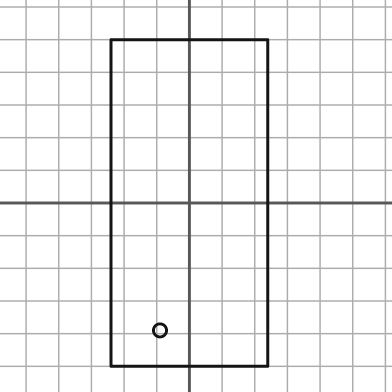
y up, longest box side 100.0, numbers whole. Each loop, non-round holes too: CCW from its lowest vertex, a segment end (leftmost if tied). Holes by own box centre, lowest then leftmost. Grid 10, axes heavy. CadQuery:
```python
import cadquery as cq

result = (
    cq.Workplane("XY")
    .moveTo(-24.0, -50.0)
    .lineTo(24.0, -50.0)
    .lineTo(24.0, 50.0)
    .lineTo(-24.0, 50.0)
    .close()
    .moveTo(-9.0, -39.0)
    .circle(2.0)
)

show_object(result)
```